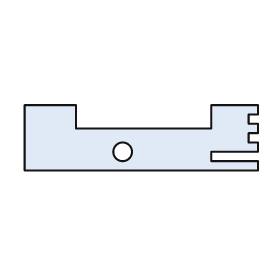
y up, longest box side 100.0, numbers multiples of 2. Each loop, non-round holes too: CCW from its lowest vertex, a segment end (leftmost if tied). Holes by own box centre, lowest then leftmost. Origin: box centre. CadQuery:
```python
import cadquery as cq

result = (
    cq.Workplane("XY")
    .moveTo(-50.0, -14.0)
    .lineTo(50.0, -14.0)
    .lineTo(50.0, -10.0)
    .lineTo(30.0, -10.0)
    .lineTo(30.0, -6.0)
    .lineTo(50.0, -6.0)
    .lineTo(50.0, -2.0)
    .lineTo(46.0, -2.0)
    .lineTo(46.0, 2.0)
    .lineTo(50.0, 2.0)
    .lineTo(50.0, 6.0)
    .lineTo(46.0, 6.0)
    .lineTo(46.0, 10.0)
    .lineTo(50.0, 10.0)
    .lineTo(50.0, 14.0)
    .lineTo(30.0, 14.0)
    .lineTo(30.0, 4.0)
    .lineTo(-28.0, 4.0)
    .lineTo(-28.0, 14.0)
    .lineTo(-50.0, 14.0)
    .close()
    .moveTo(-8.0, -6.0)
    .circle(4.0)
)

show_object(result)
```